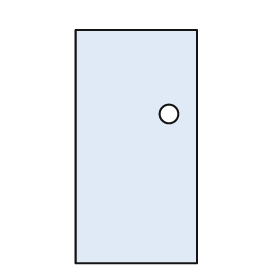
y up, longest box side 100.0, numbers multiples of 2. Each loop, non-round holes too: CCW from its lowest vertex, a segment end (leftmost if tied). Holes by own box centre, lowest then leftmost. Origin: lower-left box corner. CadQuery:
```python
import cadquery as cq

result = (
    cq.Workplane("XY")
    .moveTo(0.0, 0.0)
    .lineTo(52.0, 0.0)
    .lineTo(52.0, 100.0)
    .lineTo(0.0, 100.0)
    .close()
    .moveTo(40.0, 64.0)
    .circle(4.0)
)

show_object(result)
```